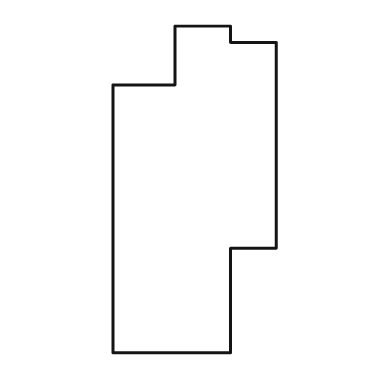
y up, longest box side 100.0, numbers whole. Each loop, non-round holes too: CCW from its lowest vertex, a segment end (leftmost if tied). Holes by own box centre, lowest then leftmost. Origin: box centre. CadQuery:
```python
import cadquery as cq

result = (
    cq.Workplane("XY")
    .moveTo(-25.0, -50.0)
    .lineTo(11.0, -50.0)
    .lineTo(11.0, -18.0)
    .lineTo(25.0, -18.0)
    .lineTo(25.0, 45.0)
    .lineTo(11.0, 45.0)
    .lineTo(11.0, 50.0)
    .lineTo(-6.0, 50.0)
    .lineTo(-6.0, 32.0)
    .lineTo(-25.0, 32.0)
    .close()
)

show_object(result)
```